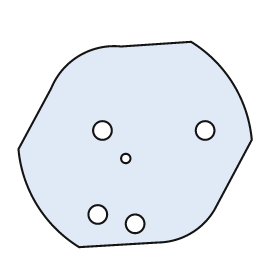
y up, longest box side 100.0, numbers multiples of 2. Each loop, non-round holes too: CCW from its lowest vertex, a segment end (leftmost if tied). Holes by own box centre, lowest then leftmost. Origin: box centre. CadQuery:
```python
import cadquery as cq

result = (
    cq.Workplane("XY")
    .moveTo(-24.0, -44.0)
    .lineTo(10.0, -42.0)
    .threePointArc((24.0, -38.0), (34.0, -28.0))
    .lineTo(50.0, 2.0)
    .threePointArc((42.0, 26.0), (24.0, 44.0))
    .lineTo(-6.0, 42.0)
    .threePointArc((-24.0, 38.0), (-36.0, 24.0))
    .lineTo(-50.0, -2.0)
    .threePointArc((-42.0, -26.0), (-24.0, -44.0))
    .close()
    .moveTo(0.0, -34.0)
    .circle(4.0)
    .moveTo(-16.0, -30.0)
    .circle(4.0)
    .moveTo(-4.0, -6.0)
    .circle(2.0)
    .moveTo(-14.0, 6.0)
    .circle(4.0)
    .moveTo(30.0, 6.0)
    .circle(4.0)
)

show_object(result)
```